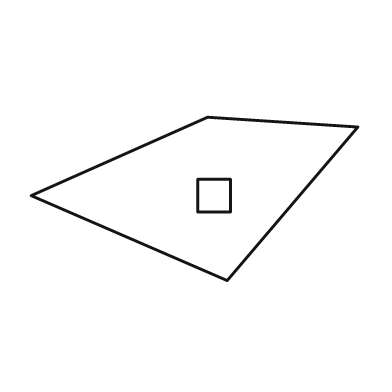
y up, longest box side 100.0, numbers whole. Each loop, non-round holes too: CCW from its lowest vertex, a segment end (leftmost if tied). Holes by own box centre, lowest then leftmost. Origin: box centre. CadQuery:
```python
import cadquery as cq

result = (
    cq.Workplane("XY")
    .moveTo(10.0, -25.0)
    .lineTo(50.0, 22.0)
    .lineTo(4.0, 25.0)
    .lineTo(-50.0, 1.0)
    .close()
    .moveTo(1.0, -4.0)
    .lineTo(11.0, -4.0)
    .lineTo(11.0, 6.0)
    .lineTo(1.0, 6.0)
    .close()
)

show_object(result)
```